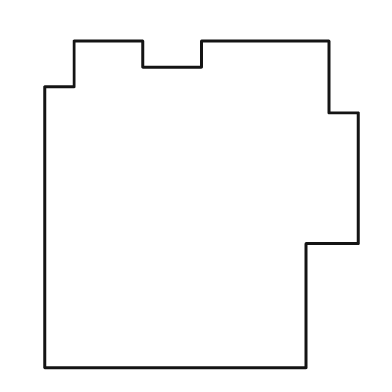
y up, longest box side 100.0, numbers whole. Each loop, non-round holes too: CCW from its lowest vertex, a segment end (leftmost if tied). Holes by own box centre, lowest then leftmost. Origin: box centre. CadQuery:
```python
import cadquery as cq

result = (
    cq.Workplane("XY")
    .moveTo(-48.0, -50.0)
    .lineTo(32.0, -50.0)
    .lineTo(32.0, -12.0)
    .lineTo(48.0, -12.0)
    .lineTo(48.0, 28.0)
    .lineTo(39.0, 28.0)
    .lineTo(39.0, 50.0)
    .lineTo(0.0, 50.0)
    .lineTo(0.0, 42.0)
    .lineTo(-18.0, 42.0)
    .lineTo(-18.0, 50.0)
    .lineTo(-39.0, 50.0)
    .lineTo(-39.0, 36.0)
    .lineTo(-48.0, 36.0)
    .close()
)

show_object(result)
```